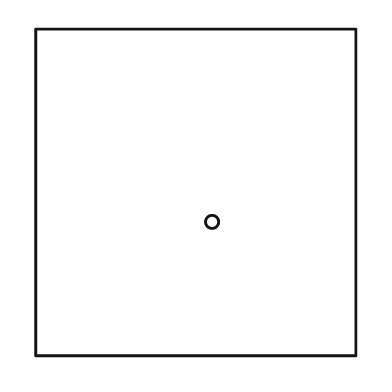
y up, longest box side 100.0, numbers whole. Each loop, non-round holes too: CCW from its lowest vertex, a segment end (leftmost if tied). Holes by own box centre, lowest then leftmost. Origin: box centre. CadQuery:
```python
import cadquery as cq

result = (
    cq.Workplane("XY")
    .moveTo(-49.0, -50.0)
    .lineTo(49.0, -50.0)
    .lineTo(49.0, 50.0)
    .lineTo(-49.0, 50.0)
    .close()
    .moveTo(5.0, -9.0)
    .circle(2.0)
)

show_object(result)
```